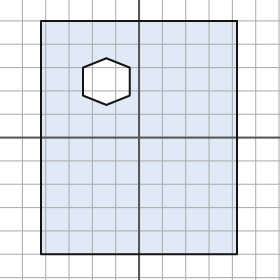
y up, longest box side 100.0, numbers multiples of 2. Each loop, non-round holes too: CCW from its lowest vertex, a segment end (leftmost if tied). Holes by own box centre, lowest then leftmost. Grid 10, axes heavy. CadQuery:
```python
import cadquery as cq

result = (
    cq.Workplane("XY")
    .moveTo(-42.0, -50.0)
    .lineTo(42.0, -50.0)
    .lineTo(42.0, 50.0)
    .lineTo(-42.0, 50.0)
    .close()
    .moveTo(-14.0, 14.0)
    .lineTo(-4.0, 18.0)
    .lineTo(-4.0, 30.0)
    .lineTo(-14.0, 34.0)
    .lineTo(-24.0, 30.0)
    .lineTo(-24.0, 18.0)
    .close()
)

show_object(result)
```